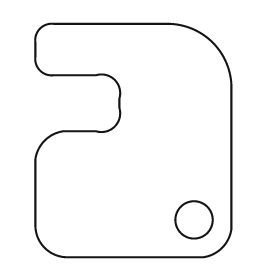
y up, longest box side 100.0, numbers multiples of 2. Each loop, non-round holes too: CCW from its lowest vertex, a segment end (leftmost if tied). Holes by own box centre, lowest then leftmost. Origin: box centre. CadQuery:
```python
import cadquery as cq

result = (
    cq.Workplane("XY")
    .moveTo(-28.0, -50.0)
    .lineTo(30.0, -50.0)
    .threePointArc((38.0, -46.0), (42.0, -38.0))
    .lineTo(42.0, 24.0)
    .threePointArc((34.0, 42.0), (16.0, 50.0))
    .lineTo(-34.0, 50.0)
    .threePointArc((-40.0, 48.0), (-42.0, 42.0))
    .lineTo(-42.0, 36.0)
    .threePointArc((-40.0, 30.0), (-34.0, 28.0))
    .lineTo(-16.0, 28.0)
    .threePointArc((-8.0, 26.0), (-6.0, 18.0))
    .lineTo(-6.0, 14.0)
    .threePointArc((-8.0, 6.0), (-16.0, 4.0))
    .lineTo(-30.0, 4.0)
    .threePointArc((-38.0, 0.0), (-42.0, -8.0))
    .lineTo(-42.0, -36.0)
    .threePointArc((-38.0, -46.0), (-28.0, -50.0))
    .close()
    .moveTo(26.0, -34.0)
    .circle(8.0)
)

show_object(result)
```